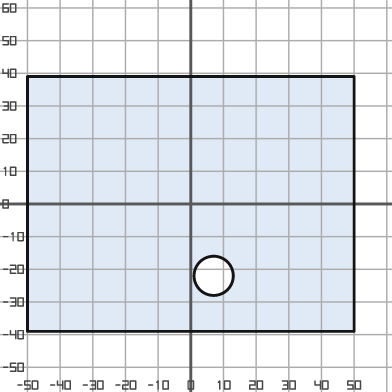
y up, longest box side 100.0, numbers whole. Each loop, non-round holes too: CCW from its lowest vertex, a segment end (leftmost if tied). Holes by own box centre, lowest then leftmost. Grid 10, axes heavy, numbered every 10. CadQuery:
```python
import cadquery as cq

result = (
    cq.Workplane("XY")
    .moveTo(-50.0, -39.0)
    .lineTo(50.0, -39.0)
    .lineTo(50.0, 39.0)
    .lineTo(-50.0, 39.0)
    .close()
    .moveTo(7.0, -22.0)
    .circle(6.0)
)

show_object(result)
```